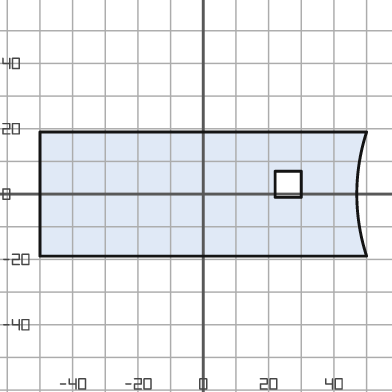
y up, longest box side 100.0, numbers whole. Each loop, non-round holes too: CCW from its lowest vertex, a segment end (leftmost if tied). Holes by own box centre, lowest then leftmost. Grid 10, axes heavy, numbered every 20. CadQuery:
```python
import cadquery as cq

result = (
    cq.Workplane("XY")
    .moveTo(-50.0, -19.0)
    .lineTo(50.0, -19.0)
    .threePointArc((47.0, 0.0), (50.0, 19.0))
    .lineTo(-50.0, 19.0)
    .close()
    .moveTo(22.0, -1.0)
    .lineTo(30.0, -1.0)
    .lineTo(30.0, 7.0)
    .lineTo(22.0, 7.0)
    .close()
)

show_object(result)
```